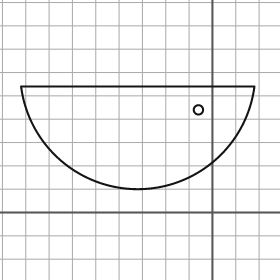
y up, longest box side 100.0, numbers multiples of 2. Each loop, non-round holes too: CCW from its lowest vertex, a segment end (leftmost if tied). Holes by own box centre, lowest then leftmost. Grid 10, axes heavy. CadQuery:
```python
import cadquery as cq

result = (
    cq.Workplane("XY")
    .moveTo(-82.0, 54.0)
    .threePointArc((-32.0, 10.0), (18.0, 54.0))
    .close()
    .moveTo(-6.0, 44.0)
    .circle(2.0)
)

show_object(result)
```